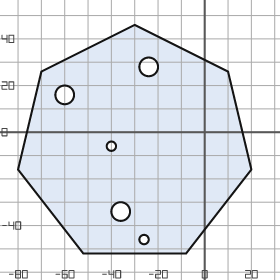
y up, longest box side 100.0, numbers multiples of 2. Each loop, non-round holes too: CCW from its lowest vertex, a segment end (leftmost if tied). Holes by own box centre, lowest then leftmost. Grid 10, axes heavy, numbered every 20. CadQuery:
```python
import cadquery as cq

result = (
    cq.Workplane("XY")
    .moveTo(-52.0, -52.0)
    .lineTo(-8.0, -52.0)
    .lineTo(20.0, -16.0)
    .lineTo(10.0, 26.0)
    .lineTo(-30.0, 46.0)
    .lineTo(-70.0, 26.0)
    .lineTo(-80.0, -16.0)
    .close()
    .moveTo(-26.0, -46.0)
    .circle(2.0)
    .moveTo(-36.0, -34.0)
    .circle(4.0)
    .moveTo(-40.0, -6.0)
    .circle(2.0)
    .moveTo(-60.0, 16.0)
    .circle(4.0)
    .moveTo(-24.0, 28.0)
    .circle(4.0)
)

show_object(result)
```